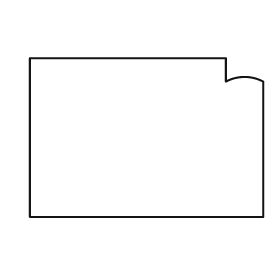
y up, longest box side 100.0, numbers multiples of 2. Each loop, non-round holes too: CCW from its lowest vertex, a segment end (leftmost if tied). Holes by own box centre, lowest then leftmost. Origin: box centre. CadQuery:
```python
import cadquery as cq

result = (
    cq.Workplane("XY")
    .moveTo(-50.0, -34.0)
    .lineTo(50.0, -34.0)
    .lineTo(50.0, 24.0)
    .threePointArc((42.0, 26.0), (34.0, 24.0))
    .lineTo(34.0, 34.0)
    .lineTo(-50.0, 34.0)
    .close()
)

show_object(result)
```